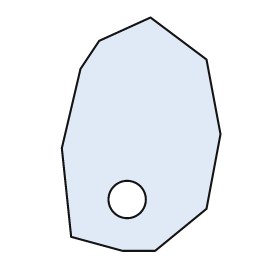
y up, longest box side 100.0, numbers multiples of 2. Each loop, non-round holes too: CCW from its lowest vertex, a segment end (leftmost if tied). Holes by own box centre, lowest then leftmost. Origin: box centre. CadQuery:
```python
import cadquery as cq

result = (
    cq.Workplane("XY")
    .moveTo(-8.0, -50.0)
    .lineTo(6.0, -50.0)
    .lineTo(28.0, -32.0)
    .lineTo(34.0, 0.0)
    .lineTo(28.0, 32.0)
    .lineTo(4.0, 50.0)
    .lineTo(-18.0, 40.0)
    .lineTo(-26.0, 28.0)
    .lineTo(-34.0, -6.0)
    .lineTo(-30.0, -44.0)
    .close()
    .moveTo(-6.0, -28.0)
    .circle(8.0)
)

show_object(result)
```